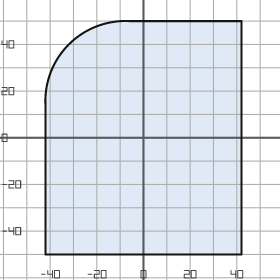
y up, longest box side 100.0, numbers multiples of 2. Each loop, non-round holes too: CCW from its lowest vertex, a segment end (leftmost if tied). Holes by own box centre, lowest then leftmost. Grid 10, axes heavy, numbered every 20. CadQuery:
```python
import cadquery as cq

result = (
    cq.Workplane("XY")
    .moveTo(-42.0, -50.0)
    .lineTo(42.0, -50.0)
    .lineTo(42.0, 50.0)
    .lineTo(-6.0, 50.0)
    .threePointArc((-32.0, 40.0), (-42.0, 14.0))
    .close()
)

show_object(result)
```